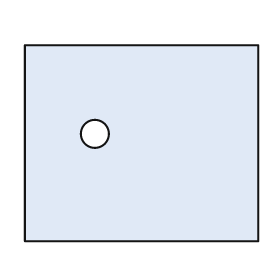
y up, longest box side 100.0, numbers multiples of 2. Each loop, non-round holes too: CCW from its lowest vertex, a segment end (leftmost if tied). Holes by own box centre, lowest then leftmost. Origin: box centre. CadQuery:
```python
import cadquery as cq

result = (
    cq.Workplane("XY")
    .moveTo(-50.0, -42.0)
    .lineTo(50.0, -42.0)
    .lineTo(50.0, 42.0)
    .lineTo(-50.0, 42.0)
    .close()
    .moveTo(-20.0, 4.0)
    .circle(6.0)
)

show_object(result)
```